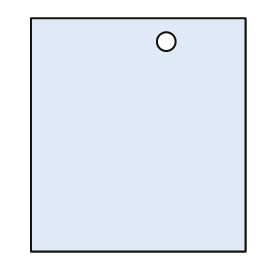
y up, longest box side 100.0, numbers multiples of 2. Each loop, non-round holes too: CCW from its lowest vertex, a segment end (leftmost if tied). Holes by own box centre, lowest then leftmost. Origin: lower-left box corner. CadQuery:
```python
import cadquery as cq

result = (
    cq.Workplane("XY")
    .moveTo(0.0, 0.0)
    .lineTo(92.0, 0.0)
    .lineTo(92.0, 100.0)
    .lineTo(0.0, 100.0)
    .close()
    .moveTo(58.0, 90.0)
    .circle(4.0)
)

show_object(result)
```